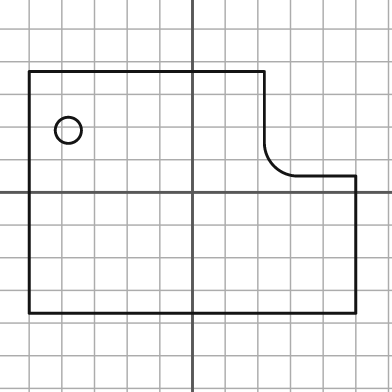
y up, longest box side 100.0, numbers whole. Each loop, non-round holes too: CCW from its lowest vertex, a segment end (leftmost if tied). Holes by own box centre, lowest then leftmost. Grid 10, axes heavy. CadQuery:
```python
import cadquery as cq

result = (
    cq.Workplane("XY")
    .moveTo(-50.0, -37.0)
    .lineTo(50.0, -37.0)
    .lineTo(50.0, 5.0)
    .lineTo(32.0, 5.0)
    .threePointArc((25.0, 8.0), (22.0, 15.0))
    .lineTo(22.0, 37.0)
    .lineTo(-50.0, 37.0)
    .close()
    .moveTo(-38.0, 19.0)
    .circle(4.0)
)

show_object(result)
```